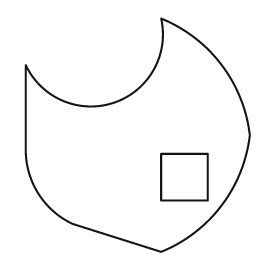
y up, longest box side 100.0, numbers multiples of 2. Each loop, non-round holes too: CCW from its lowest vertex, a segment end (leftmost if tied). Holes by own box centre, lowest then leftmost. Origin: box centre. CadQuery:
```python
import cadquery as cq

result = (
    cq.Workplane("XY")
    .moveTo(10.0, -50.0)
    .threePointArc((36.0, -30.0), (48.0, 0.0))
    .threePointArc((36.0, 30.0), (10.0, 50.0))
    .threePointArc((-10.0, 14.0), (-48.0, 30.0))
    .lineTo(-48.0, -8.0)
    .threePointArc((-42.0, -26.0), (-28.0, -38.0))
    .close()
    .moveTo(10.0, -28.0)
    .lineTo(30.0, -28.0)
    .lineTo(30.0, -8.0)
    .lineTo(10.0, -8.0)
    .close()
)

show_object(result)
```